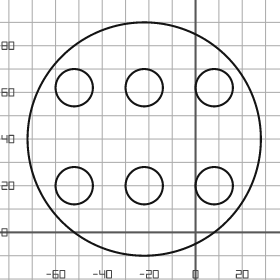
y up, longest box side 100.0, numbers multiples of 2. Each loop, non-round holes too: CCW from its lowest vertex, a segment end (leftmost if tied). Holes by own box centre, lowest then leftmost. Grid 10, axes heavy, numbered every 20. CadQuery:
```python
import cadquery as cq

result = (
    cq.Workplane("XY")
    .moveTo(-22.0, 40.0)
    .circle(50.0)
    .moveTo(-52.0, 20.0)
    .circle(8.0)
    .moveTo(-22.0, 20.0)
    .circle(8.0)
    .moveTo(8.0, 20.0)
    .circle(8.0)
    .moveTo(-52.0, 62.0)
    .circle(8.0)
    .moveTo(-22.0, 62.0)
    .circle(8.0)
    .moveTo(8.0, 62.0)
    .circle(8.0)
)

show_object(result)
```